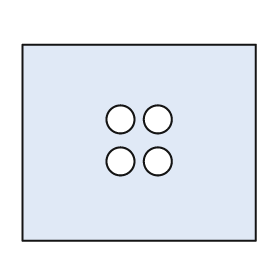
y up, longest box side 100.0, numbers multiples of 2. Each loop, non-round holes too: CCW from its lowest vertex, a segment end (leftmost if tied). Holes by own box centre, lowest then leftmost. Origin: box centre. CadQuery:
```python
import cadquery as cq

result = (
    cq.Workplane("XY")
    .moveTo(-50.0, -42.0)
    .lineTo(50.0, -42.0)
    .lineTo(50.0, 42.0)
    .lineTo(-50.0, 42.0)
    .close()
    .moveTo(-8.0, -8.0)
    .circle(6.0)
    .moveTo(8.0, -8.0)
    .circle(6.0)
    .moveTo(-8.0, 10.0)
    .circle(6.0)
    .moveTo(8.0, 10.0)
    .circle(6.0)
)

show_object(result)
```